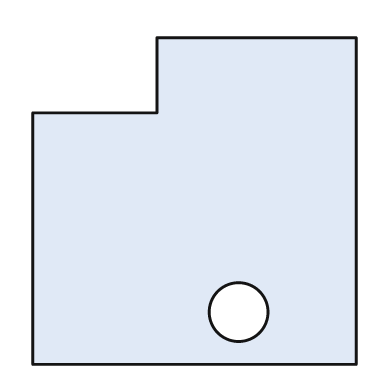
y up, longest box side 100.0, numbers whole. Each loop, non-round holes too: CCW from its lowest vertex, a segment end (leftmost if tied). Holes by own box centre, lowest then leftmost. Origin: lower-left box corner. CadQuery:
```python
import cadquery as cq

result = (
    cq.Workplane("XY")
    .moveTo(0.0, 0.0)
    .lineTo(99.0, 0.0)
    .lineTo(99.0, 100.0)
    .lineTo(38.0, 100.0)
    .lineTo(38.0, 77.0)
    .lineTo(0.0, 77.0)
    .close()
    .moveTo(63.0, 16.0)
    .circle(9.0)
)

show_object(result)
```